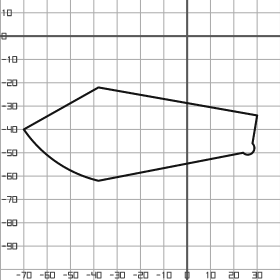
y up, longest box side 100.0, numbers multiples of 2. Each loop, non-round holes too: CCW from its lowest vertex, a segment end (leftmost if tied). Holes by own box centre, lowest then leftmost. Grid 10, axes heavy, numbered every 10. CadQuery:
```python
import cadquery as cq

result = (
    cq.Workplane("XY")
    .moveTo(-38.0, -62.0)
    .lineTo(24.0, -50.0)
    .threePointArc((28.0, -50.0), (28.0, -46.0))
    .lineTo(30.0, -34.0)
    .lineTo(-38.0, -22.0)
    .lineTo(-70.0, -40.0)
    .threePointArc((-56.0, -54.0), (-38.0, -62.0))
    .close()
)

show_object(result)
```